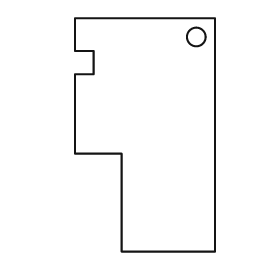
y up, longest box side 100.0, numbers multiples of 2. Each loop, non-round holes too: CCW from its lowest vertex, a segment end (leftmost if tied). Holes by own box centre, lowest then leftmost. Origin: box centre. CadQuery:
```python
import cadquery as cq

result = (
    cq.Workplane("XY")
    .moveTo(-10.0, -50.0)
    .lineTo(30.0, -50.0)
    .lineTo(30.0, 50.0)
    .lineTo(-30.0, 50.0)
    .lineTo(-30.0, 36.0)
    .lineTo(-22.0, 36.0)
    .lineTo(-22.0, 26.0)
    .lineTo(-30.0, 26.0)
    .lineTo(-30.0, -8.0)
    .lineTo(-10.0, -8.0)
    .close()
    .moveTo(22.0, 42.0)
    .circle(4.0)
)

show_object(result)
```